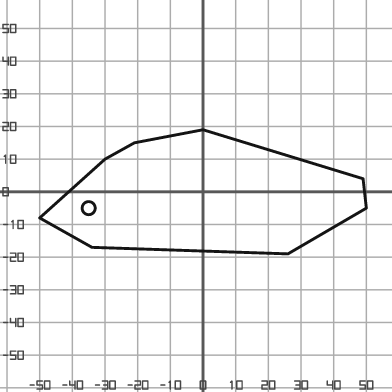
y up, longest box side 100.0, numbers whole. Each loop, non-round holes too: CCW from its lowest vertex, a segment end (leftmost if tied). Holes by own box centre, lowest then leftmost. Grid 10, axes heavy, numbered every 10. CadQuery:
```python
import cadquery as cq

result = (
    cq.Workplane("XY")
    .moveTo(26.0, -19.0)
    .lineTo(50.0, -5.0)
    .lineTo(49.0, 4.0)
    .lineTo(0.0, 19.0)
    .lineTo(-21.0, 15.0)
    .lineTo(-30.0, 10.0)
    .lineTo(-50.0, -8.0)
    .lineTo(-34.0, -17.0)
    .close()
    .moveTo(-35.0, -5.0)
    .circle(2.0)
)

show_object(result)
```